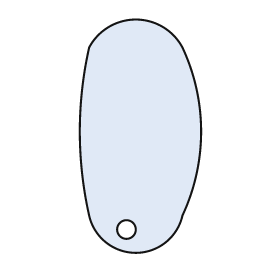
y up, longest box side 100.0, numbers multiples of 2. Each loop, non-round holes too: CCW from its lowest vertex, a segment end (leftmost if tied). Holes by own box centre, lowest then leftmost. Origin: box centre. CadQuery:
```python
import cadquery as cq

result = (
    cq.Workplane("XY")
    .moveTo(-22.0, -34.0)
    .threePointArc((-2.0, -50.0), (18.0, -34.0))
    .threePointArc((26.0, 2.0), (18.0, 38.0))
    .threePointArc((-2.0, 50.0), (-22.0, 38.0))
    .threePointArc((-26.0, 2.0), (-22.0, -34.0))
    .close()
    .moveTo(-6.0, -40.0)
    .circle(4.0)
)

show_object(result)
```